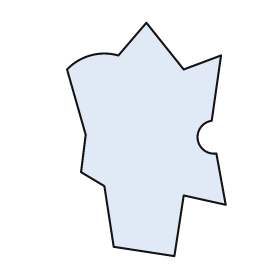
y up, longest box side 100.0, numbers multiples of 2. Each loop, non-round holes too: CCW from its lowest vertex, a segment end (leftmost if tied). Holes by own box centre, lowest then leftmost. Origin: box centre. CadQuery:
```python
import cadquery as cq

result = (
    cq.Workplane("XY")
    .moveTo(12.0, -50.0)
    .lineTo(16.0, -24.0)
    .lineTo(34.0, -28.0)
    .lineTo(30.0, -6.0)
    .threePointArc((22.0, 0.0), (28.0, 8.0))
    .lineTo(32.0, 36.0)
    .lineTo(16.0, 30.0)
    .lineTo(0.0, 50.0)
    .lineTo(-12.0, 36.0)
    .threePointArc((-24.0, 36.0), (-34.0, 30.0))
    .lineTo(-26.0, 2.0)
    .lineTo(-28.0, -14.0)
    .lineTo(-18.0, -20.0)
    .lineTo(-14.0, -46.0)
    .close()
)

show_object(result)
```